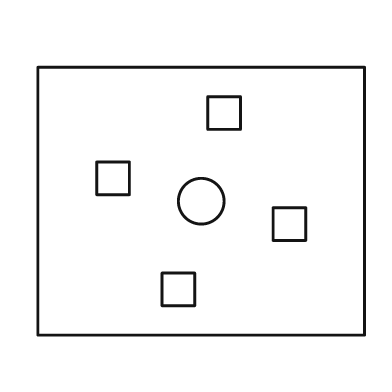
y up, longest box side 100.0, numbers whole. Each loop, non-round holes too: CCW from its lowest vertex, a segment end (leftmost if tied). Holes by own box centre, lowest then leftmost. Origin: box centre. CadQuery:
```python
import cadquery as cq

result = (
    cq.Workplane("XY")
    .moveTo(-50.0, -41.0)
    .lineTo(50.0, -41.0)
    .lineTo(50.0, 41.0)
    .lineTo(-50.0, 41.0)
    .close()
    .moveTo(-12.0, -32.0)
    .lineTo(-2.0, -32.0)
    .lineTo(-2.0, -22.0)
    .lineTo(-12.0, -22.0)
    .close()
    .moveTo(22.0, -12.0)
    .lineTo(32.0, -12.0)
    .lineTo(32.0, -2.0)
    .lineTo(22.0, -2.0)
    .close()
    .moveTo(0.0, 0.0)
    .circle(7.0)
    .moveTo(-32.0, 2.0)
    .lineTo(-22.0, 2.0)
    .lineTo(-22.0, 12.0)
    .lineTo(-32.0, 12.0)
    .close()
    .moveTo(2.0, 22.0)
    .lineTo(12.0, 22.0)
    .lineTo(12.0, 32.0)
    .lineTo(2.0, 32.0)
    .close()
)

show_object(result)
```